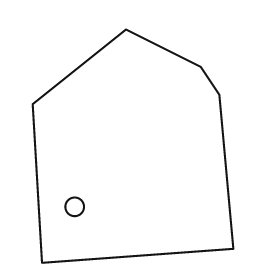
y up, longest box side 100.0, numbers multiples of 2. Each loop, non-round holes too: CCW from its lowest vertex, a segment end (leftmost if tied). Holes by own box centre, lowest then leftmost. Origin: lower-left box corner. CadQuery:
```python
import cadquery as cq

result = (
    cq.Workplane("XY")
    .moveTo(4.0, 0.0)
    .lineTo(86.0, 6.0)
    .lineTo(80.0, 72.0)
    .lineTo(72.0, 84.0)
    .lineTo(40.0, 100.0)
    .lineTo(0.0, 68.0)
    .close()
    .moveTo(18.0, 24.0)
    .circle(4.0)
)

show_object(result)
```